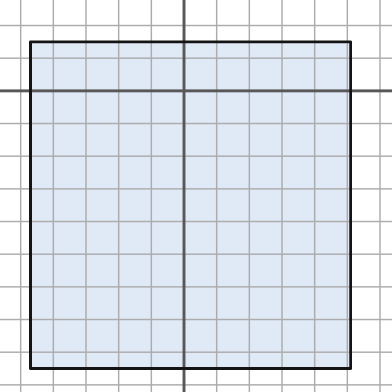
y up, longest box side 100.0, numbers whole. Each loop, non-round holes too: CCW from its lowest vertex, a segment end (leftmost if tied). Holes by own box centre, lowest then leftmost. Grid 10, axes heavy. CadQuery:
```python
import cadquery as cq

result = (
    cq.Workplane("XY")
    .moveTo(-47.0, -85.0)
    .lineTo(51.0, -85.0)
    .lineTo(51.0, 15.0)
    .lineTo(-47.0, 15.0)
    .close()
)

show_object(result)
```